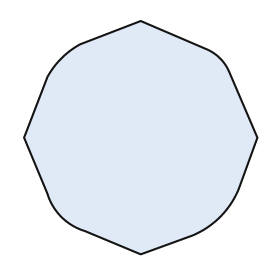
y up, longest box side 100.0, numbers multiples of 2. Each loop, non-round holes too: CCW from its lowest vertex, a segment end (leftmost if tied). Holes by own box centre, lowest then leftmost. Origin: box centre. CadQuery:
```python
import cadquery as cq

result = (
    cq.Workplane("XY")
    .moveTo(0.0, -50.0)
    .lineTo(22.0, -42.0)
    .threePointArc((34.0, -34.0), (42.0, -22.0))
    .lineTo(50.0, 0.0)
    .lineTo(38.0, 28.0)
    .threePointArc((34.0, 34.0), (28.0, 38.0))
    .lineTo(0.0, 50.0)
    .lineTo(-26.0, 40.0)
    .threePointArc((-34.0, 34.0), (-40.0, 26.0))
    .lineTo(-50.0, 0.0)
    .lineTo(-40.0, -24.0)
    .threePointArc((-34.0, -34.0), (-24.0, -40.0))
    .close()
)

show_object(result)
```